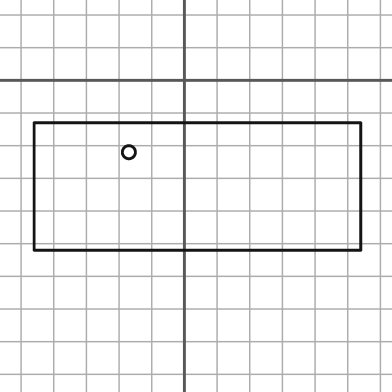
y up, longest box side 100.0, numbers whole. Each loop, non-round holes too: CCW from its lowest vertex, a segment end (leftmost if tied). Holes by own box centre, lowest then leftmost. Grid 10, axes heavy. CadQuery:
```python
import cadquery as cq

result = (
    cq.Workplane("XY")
    .moveTo(-46.0, -52.0)
    .lineTo(54.0, -52.0)
    .lineTo(54.0, -13.0)
    .lineTo(-46.0, -13.0)
    .close()
    .moveTo(-17.0, -22.0)
    .circle(2.0)
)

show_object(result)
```